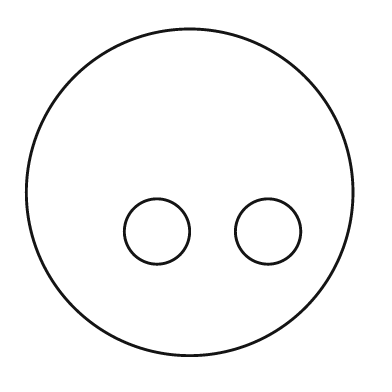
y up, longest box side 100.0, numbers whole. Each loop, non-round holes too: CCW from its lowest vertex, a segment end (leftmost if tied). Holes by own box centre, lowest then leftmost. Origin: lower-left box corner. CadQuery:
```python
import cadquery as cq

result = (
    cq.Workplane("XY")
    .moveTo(50.0, 50.0)
    .circle(50.0)
    .moveTo(40.0, 38.0)
    .circle(10.0)
    .moveTo(74.0, 38.0)
    .circle(10.0)
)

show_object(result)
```